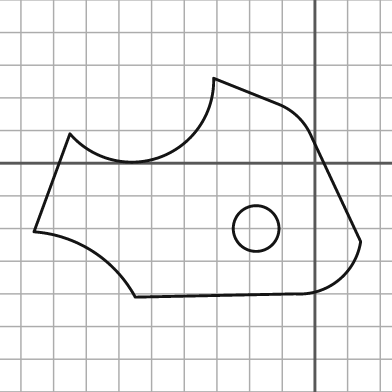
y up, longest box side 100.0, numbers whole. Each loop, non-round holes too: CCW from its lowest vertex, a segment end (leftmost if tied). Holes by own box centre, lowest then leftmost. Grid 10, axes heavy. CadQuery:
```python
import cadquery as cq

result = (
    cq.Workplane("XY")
    .moveTo(-55.0, -41.0)
    .lineTo(-6.0, -40.0)
    .threePointArc((7.0, -36.0), (14.0, -24.0))
    .lineTo(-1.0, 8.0)
    .threePointArc((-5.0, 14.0), (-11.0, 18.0))
    .lineTo(-31.0, 26.0)
    .threePointArc((-47.0, 2.0), (-75.0, 9.0))
    .lineTo(-86.0, -21.0)
    .threePointArc((-68.0, -27.0), (-55.0, -41.0))
    .close()
    .moveTo(-18.0, -20.0)
    .circle(7.0)
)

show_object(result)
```